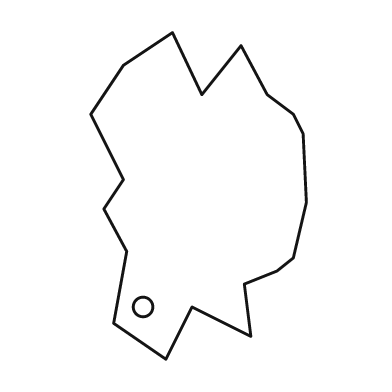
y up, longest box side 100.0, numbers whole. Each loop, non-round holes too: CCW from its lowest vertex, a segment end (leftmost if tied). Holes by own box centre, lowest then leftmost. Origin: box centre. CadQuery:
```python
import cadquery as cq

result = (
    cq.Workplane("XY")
    .moveTo(-10.0, -50.0)
    .lineTo(-2.0, -34.0)
    .lineTo(16.0, -43.0)
    .lineTo(14.0, -27.0)
    .lineTo(24.0, -23.0)
    .lineTo(29.0, -19.0)
    .lineTo(33.0, -2.0)
    .lineTo(32.0, 19.0)
    .lineTo(29.0, 25.0)
    .lineTo(21.0, 31.0)
    .lineTo(13.0, 46.0)
    .lineTo(1.0, 31.0)
    .lineTo(-8.0, 50.0)
    .lineTo(-23.0, 40.0)
    .lineTo(-33.0, 25.0)
    .lineTo(-23.0, 5.0)
    .lineTo(-29.0, -4.0)
    .lineTo(-22.0, -17.0)
    .lineTo(-26.0, -39.0)
    .close()
    .moveTo(-17.0, -34.0)
    .circle(3.0)
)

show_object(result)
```